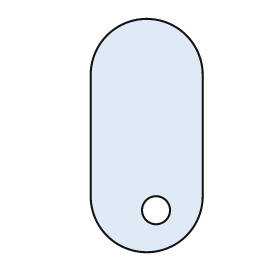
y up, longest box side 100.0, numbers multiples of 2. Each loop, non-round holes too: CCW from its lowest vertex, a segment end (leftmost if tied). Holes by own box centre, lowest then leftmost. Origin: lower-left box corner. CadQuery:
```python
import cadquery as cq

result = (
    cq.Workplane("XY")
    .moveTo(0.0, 24.0)
    .threePointArc((24.0, 0.0), (48.0, 24.0))
    .lineTo(48.0, 76.0)
    .threePointArc((24.0, 100.0), (0.0, 76.0))
    .close()
    .moveTo(28.0, 18.0)
    .circle(6.0)
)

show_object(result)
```